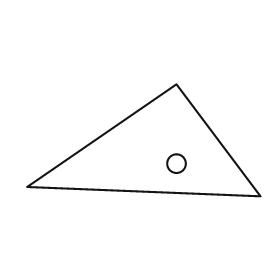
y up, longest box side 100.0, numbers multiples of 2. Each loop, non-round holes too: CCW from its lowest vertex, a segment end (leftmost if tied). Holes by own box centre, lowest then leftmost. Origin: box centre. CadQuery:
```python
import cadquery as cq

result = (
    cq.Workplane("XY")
    .moveTo(50.0, -24.0)
    .lineTo(14.0, 24.0)
    .lineTo(-50.0, -20.0)
    .close()
    .moveTo(14.0, -10.0)
    .circle(4.0)
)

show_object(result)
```